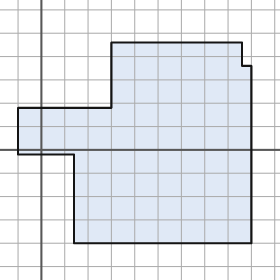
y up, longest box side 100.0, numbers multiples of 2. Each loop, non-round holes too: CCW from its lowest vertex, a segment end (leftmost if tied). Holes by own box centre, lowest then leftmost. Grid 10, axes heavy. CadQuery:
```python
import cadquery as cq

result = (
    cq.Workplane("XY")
    .moveTo(14.0, -40.0)
    .lineTo(90.0, -40.0)
    .lineTo(90.0, 36.0)
    .lineTo(86.0, 36.0)
    .lineTo(86.0, 46.0)
    .lineTo(30.0, 46.0)
    .lineTo(30.0, 18.0)
    .lineTo(-10.0, 18.0)
    .lineTo(-10.0, -2.0)
    .lineTo(14.0, -2.0)
    .close()
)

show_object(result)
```